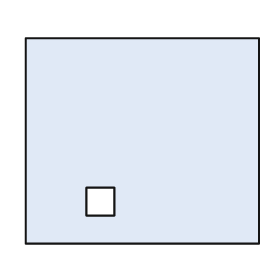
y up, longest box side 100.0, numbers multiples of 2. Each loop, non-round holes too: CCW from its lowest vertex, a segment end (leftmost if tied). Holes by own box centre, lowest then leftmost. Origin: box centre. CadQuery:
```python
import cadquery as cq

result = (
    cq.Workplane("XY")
    .moveTo(-50.0, -44.0)
    .lineTo(50.0, -44.0)
    .lineTo(50.0, 44.0)
    .lineTo(-50.0, 44.0)
    .close()
    .moveTo(-24.0, -32.0)
    .lineTo(-12.0, -32.0)
    .lineTo(-12.0, -20.0)
    .lineTo(-24.0, -20.0)
    .close()
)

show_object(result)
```